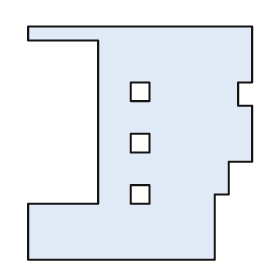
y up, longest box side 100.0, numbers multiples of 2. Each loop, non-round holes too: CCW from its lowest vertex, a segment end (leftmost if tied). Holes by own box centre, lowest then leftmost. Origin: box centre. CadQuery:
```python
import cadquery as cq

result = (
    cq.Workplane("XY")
    .moveTo(-48.0, -50.0)
    .lineTo(32.0, -50.0)
    .lineTo(32.0, -22.0)
    .lineTo(38.0, -22.0)
    .lineTo(38.0, -8.0)
    .lineTo(48.0, -8.0)
    .lineTo(48.0, 16.0)
    .lineTo(42.0, 16.0)
    .lineTo(42.0, 26.0)
    .lineTo(48.0, 26.0)
    .lineTo(48.0, 50.0)
    .lineTo(-48.0, 50.0)
    .lineTo(-48.0, 44.0)
    .lineTo(-18.0, 44.0)
    .lineTo(-18.0, -26.0)
    .lineTo(-48.0, -26.0)
    .close()
    .moveTo(-4.0, -26.0)
    .lineTo(4.0, -26.0)
    .lineTo(4.0, -18.0)
    .lineTo(-4.0, -18.0)
    .close()
    .moveTo(-4.0, -4.0)
    .lineTo(4.0, -4.0)
    .lineTo(4.0, 4.0)
    .lineTo(-4.0, 4.0)
    .close()
    .moveTo(-4.0, 18.0)
    .lineTo(4.0, 18.0)
    .lineTo(4.0, 26.0)
    .lineTo(-4.0, 26.0)
    .close()
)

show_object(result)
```